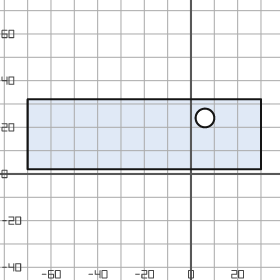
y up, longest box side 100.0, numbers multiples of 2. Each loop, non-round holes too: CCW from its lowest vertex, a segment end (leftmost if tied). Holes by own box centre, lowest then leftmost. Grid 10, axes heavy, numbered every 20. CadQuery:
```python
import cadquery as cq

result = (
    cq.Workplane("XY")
    .moveTo(-70.0, 2.0)
    .lineTo(30.0, 2.0)
    .lineTo(30.0, 32.0)
    .lineTo(-70.0, 32.0)
    .close()
    .moveTo(6.0, 24.0)
    .circle(4.0)
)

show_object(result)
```